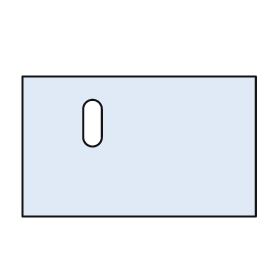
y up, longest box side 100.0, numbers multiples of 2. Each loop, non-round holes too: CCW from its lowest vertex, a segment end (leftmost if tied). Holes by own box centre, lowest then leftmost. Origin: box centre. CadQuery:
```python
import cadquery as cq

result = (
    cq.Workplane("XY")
    .moveTo(-50.0, -30.0)
    .lineTo(50.0, -30.0)
    .lineTo(50.0, 30.0)
    .lineTo(-50.0, 30.0)
    .close()
    .moveTo(-24.0, 4.0)
    .threePointArc((-20.0, 0.0), (-16.0, 4.0))
    .lineTo(-16.0, 16.0)
    .threePointArc((-20.0, 20.0), (-24.0, 16.0))
    .close()
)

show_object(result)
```